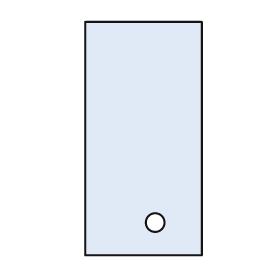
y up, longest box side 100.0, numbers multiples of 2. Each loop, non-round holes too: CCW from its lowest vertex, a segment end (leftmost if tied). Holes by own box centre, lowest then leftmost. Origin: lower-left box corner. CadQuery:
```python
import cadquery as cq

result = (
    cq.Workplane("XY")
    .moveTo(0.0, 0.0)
    .lineTo(50.0, 0.0)
    .lineTo(50.0, 100.0)
    .lineTo(0.0, 100.0)
    .close()
    .moveTo(30.0, 14.0)
    .circle(4.0)
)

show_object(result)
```